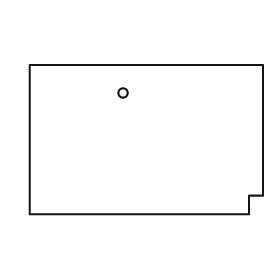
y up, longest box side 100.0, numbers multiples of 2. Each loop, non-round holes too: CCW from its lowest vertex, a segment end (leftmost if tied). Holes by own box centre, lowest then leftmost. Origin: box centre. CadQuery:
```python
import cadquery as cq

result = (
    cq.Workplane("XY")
    .moveTo(-50.0, -32.0)
    .lineTo(44.0, -32.0)
    .lineTo(44.0, -24.0)
    .lineTo(50.0, -24.0)
    .lineTo(50.0, 32.0)
    .lineTo(-50.0, 32.0)
    .close()
    .moveTo(-10.0, 20.0)
    .circle(2.0)
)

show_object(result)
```